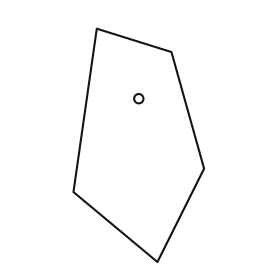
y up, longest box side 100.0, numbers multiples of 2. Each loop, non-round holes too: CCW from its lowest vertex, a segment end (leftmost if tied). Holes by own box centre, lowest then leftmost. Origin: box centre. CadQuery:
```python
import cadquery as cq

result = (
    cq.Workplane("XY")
    .moveTo(8.0, -50.0)
    .lineTo(28.0, -10.0)
    .lineTo(14.0, 40.0)
    .lineTo(-18.0, 50.0)
    .lineTo(-28.0, -20.0)
    .close()
    .moveTo(0.0, 20.0)
    .circle(2.0)
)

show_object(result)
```